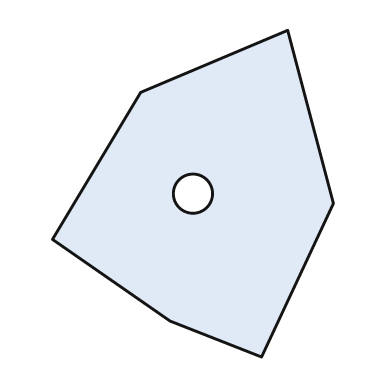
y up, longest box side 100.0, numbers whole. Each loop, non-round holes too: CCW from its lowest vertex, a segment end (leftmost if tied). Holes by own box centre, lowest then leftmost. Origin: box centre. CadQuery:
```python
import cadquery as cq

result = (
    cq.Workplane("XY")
    .moveTo(21.0, -50.0)
    .lineTo(43.0, -3.0)
    .lineTo(29.0, 50.0)
    .lineTo(-16.0, 31.0)
    .lineTo(-43.0, -14.0)
    .lineTo(-7.0, -39.0)
    .close()
    .moveTo(0.0, 0.0)
    .circle(6.0)
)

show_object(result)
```